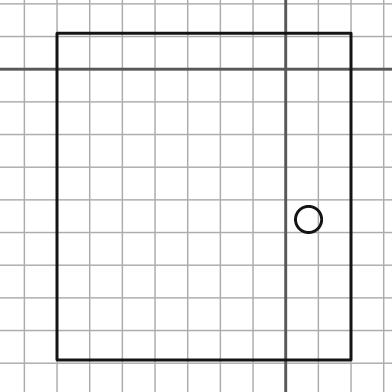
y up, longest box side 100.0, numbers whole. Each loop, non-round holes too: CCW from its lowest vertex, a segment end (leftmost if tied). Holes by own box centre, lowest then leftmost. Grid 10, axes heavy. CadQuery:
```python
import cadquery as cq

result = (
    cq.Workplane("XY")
    .moveTo(-70.0, -89.0)
    .lineTo(20.0, -89.0)
    .lineTo(20.0, 11.0)
    .lineTo(-70.0, 11.0)
    .close()
    .moveTo(7.0, -46.0)
    .circle(4.0)
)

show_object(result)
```